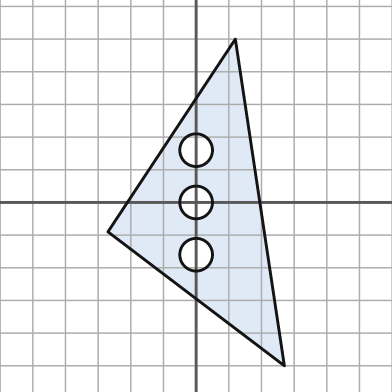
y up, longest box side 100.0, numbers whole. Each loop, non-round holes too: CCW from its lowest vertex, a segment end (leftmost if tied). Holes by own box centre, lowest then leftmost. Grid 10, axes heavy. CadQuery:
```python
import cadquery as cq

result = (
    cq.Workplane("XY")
    .moveTo(27.0, -50.0)
    .lineTo(12.0, 50.0)
    .lineTo(-27.0, -9.0)
    .close()
    .moveTo(0.0, -16.0)
    .circle(5.0)
    .moveTo(0.0, 0.0)
    .circle(5.0)
    .moveTo(0.0, 16.0)
    .circle(5.0)
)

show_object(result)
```